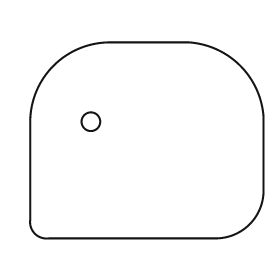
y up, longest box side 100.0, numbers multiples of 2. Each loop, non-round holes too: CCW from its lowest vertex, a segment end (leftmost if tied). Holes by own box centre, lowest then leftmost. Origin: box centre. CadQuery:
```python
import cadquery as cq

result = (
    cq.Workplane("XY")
    .moveTo(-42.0, -42.0)
    .lineTo(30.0, -42.0)
    .threePointArc((44.0, -36.0), (50.0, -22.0))
    .lineTo(50.0, 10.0)
    .threePointArc((40.0, 32.0), (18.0, 42.0))
    .lineTo(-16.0, 42.0)
    .threePointArc((-40.0, 32.0), (-50.0, 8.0))
    .lineTo(-50.0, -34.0)
    .threePointArc((-48.0, -40.0), (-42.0, -42.0))
    .close()
    .moveTo(-24.0, 8.0)
    .circle(4.0)
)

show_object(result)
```